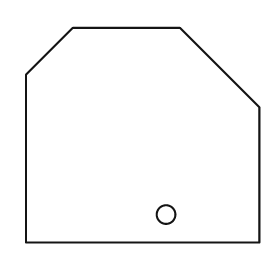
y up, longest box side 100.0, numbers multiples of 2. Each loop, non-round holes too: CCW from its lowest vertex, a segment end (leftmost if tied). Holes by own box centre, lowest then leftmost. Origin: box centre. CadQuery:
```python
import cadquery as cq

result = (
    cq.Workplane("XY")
    .moveTo(-50.0, -46.0)
    .lineTo(50.0, -46.0)
    .lineTo(50.0, 12.0)
    .lineTo(16.0, 46.0)
    .lineTo(-30.0, 46.0)
    .lineTo(-50.0, 26.0)
    .close()
    .moveTo(10.0, -34.0)
    .circle(4.0)
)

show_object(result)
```